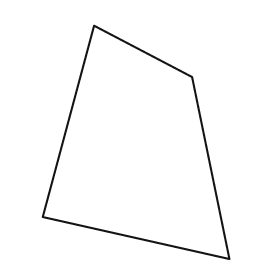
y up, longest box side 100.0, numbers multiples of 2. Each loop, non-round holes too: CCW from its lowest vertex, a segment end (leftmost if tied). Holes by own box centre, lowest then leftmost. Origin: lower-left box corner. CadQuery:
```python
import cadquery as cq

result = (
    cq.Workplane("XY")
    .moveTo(80.0, 0.0)
    .lineTo(64.0, 78.0)
    .lineTo(22.0, 100.0)
    .lineTo(0.0, 18.0)
    .close()
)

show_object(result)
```